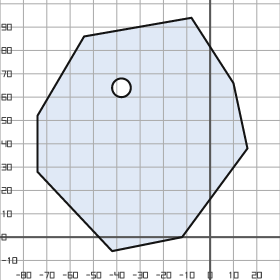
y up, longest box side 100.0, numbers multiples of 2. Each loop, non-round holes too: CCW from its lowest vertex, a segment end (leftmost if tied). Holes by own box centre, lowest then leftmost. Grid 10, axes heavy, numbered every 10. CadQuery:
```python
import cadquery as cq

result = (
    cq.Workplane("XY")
    .moveTo(-42.0, -6.0)
    .lineTo(-12.0, 0.0)
    .lineTo(16.0, 38.0)
    .lineTo(10.0, 66.0)
    .lineTo(-8.0, 94.0)
    .lineTo(-54.0, 86.0)
    .lineTo(-74.0, 52.0)
    .lineTo(-74.0, 28.0)
    .close()
    .moveTo(-38.0, 64.0)
    .circle(4.0)
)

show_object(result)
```